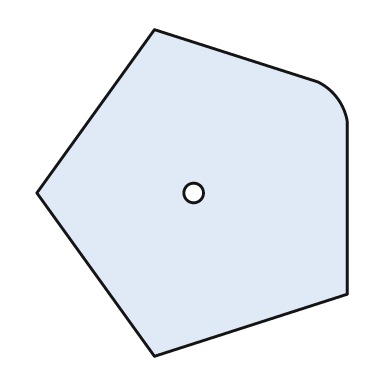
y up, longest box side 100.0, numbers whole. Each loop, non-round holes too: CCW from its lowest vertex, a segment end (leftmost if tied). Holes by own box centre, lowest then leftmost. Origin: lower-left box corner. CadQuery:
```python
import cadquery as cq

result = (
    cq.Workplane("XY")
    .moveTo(36.0, 0.0)
    .lineTo(95.0, 19.0)
    .lineTo(95.0, 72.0)
    .threePointArc((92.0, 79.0), (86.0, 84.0))
    .lineTo(36.0, 100.0)
    .lineTo(0.0, 50.0)
    .close()
    .moveTo(48.0, 50.0)
    .circle(3.0)
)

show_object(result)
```